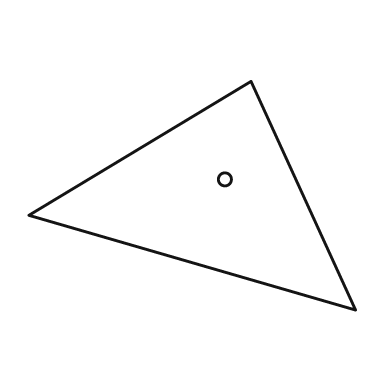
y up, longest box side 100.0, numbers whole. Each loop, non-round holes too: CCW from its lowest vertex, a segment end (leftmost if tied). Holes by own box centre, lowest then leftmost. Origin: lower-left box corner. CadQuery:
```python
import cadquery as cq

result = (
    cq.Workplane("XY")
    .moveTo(100.0, 0.0)
    .lineTo(68.0, 70.0)
    .lineTo(0.0, 29.0)
    .close()
    .moveTo(60.0, 40.0)
    .circle(2.0)
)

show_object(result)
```